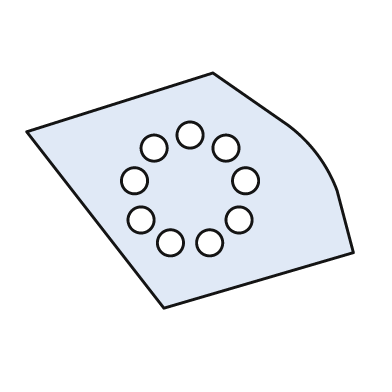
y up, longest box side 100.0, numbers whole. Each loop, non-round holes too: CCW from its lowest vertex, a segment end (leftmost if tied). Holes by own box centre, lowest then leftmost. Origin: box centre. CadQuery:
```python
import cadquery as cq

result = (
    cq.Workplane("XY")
    .moveTo(-8.0, -36.0)
    .lineTo(50.0, -19.0)
    .lineTo(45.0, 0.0)
    .threePointArc((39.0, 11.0), (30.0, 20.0))
    .lineTo(7.0, 36.0)
    .lineTo(-50.0, 18.0)
    .close()
    .moveTo(-6.0, -16.0)
    .circle(4.0)
    .moveTo(6.0, -16.0)
    .circle(4.0)
    .moveTo(-15.0, -9.0)
    .circle(4.0)
    .moveTo(15.0, -9.0)
    .circle(4.0)
    .moveTo(-17.0, 3.0)
    .circle(4.0)
    .moveTo(17.0, 3.0)
    .circle(4.0)
    .moveTo(-11.0, 13.0)
    .circle(4.0)
    .moveTo(11.0, 13.0)
    .circle(4.0)
    .moveTo(0.0, 17.0)
    .circle(4.0)
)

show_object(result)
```